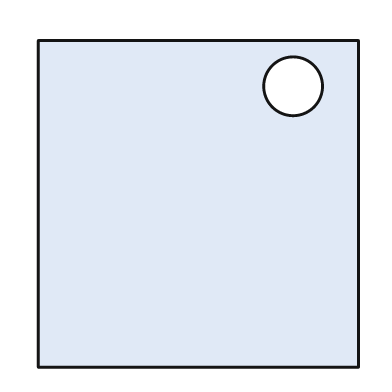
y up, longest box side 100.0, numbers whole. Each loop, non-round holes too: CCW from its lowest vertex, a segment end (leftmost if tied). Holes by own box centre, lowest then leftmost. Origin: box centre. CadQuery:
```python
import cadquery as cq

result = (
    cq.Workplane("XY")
    .moveTo(-49.0, -50.0)
    .lineTo(49.0, -50.0)
    .lineTo(49.0, 50.0)
    .lineTo(-49.0, 50.0)
    .close()
    .moveTo(29.0, 36.0)
    .circle(9.0)
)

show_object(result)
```